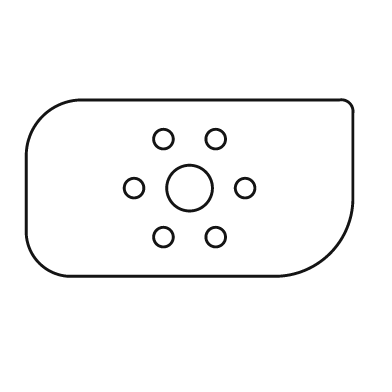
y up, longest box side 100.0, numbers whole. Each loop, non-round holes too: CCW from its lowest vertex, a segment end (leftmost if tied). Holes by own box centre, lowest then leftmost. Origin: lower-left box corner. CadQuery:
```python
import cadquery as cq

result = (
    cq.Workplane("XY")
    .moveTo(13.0, 0.0)
    .lineTo(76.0, 0.0)
    .threePointArc((93.0, 7.0), (100.0, 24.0))
    .lineTo(100.0, 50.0)
    .threePointArc((99.0, 53.0), (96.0, 54.0))
    .lineTo(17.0, 54.0)
    .threePointArc((5.0, 49.0), (0.0, 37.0))
    .lineTo(0.0, 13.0)
    .threePointArc((4.0, 4.0), (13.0, 0.0))
    .close()
    .moveTo(42.0, 12.0)
    .circle(3.0)
    .moveTo(58.0, 12.0)
    .circle(3.0)
    .moveTo(33.0, 27.0)
    .circle(3.0)
    .moveTo(50.0, 27.0)
    .circle(7.0)
    .moveTo(67.0, 27.0)
    .circle(3.0)
    .moveTo(42.0, 42.0)
    .circle(3.0)
    .moveTo(58.0, 42.0)
    .circle(3.0)
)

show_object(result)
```